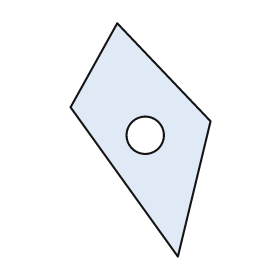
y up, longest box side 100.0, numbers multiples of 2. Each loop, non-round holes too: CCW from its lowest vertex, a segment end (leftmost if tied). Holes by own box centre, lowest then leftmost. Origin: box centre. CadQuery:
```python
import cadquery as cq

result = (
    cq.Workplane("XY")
    .moveTo(16.0, -50.0)
    .lineTo(30.0, 8.0)
    .lineTo(-10.0, 50.0)
    .lineTo(-30.0, 14.0)
    .close()
    .moveTo(2.0, 2.0)
    .circle(8.0)
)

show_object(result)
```